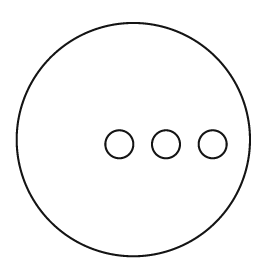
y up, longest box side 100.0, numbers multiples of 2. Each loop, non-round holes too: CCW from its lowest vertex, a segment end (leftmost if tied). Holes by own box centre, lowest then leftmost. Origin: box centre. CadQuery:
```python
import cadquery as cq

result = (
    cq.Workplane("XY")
    .moveTo(0.0, 0.0)
    .circle(50.0)
    .moveTo(-6.0, -2.0)
    .circle(6.0)
    .moveTo(14.0, -2.0)
    .circle(6.0)
    .moveTo(34.0, -2.0)
    .circle(6.0)
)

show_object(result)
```